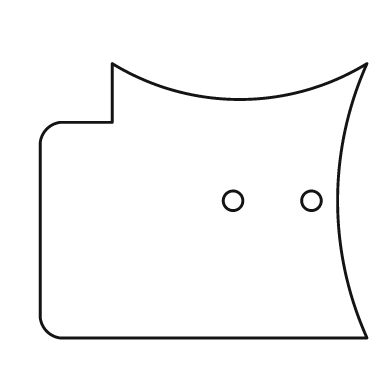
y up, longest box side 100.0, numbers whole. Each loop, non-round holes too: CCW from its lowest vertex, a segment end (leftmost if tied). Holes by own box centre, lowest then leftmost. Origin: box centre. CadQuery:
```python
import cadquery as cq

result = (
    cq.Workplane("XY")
    .moveTo(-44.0, -42.0)
    .lineTo(50.0, -42.0)
    .threePointArc((41.0, 0.0), (50.0, 42.0))
    .threePointArc((11.0, 31.0), (-28.0, 42.0))
    .lineTo(-28.0, 24.0)
    .lineTo(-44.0, 24.0)
    .threePointArc((-48.0, 22.0), (-50.0, 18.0))
    .lineTo(-50.0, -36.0)
    .threePointArc((-48.0, -40.0), (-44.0, -42.0))
    .close()
    .moveTo(9.0, 0.0)
    .circle(3.0)
    .moveTo(33.0, 0.0)
    .circle(3.0)
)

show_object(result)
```